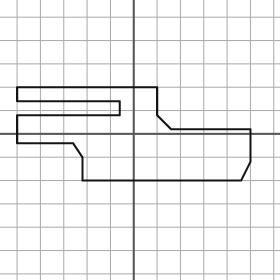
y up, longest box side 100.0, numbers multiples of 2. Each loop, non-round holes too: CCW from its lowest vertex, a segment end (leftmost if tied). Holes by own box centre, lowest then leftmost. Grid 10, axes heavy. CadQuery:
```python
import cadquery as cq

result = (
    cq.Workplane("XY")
    .moveTo(-22.0, -20.0)
    .lineTo(46.0, -20.0)
    .lineTo(50.0, -12.0)
    .lineTo(50.0, 2.0)
    .lineTo(16.0, 2.0)
    .lineTo(10.0, 8.0)
    .lineTo(10.0, 20.0)
    .lineTo(-50.0, 20.0)
    .lineTo(-50.0, 14.0)
    .lineTo(-6.0, 14.0)
    .lineTo(-6.0, 8.0)
    .lineTo(-50.0, 8.0)
    .lineTo(-50.0, -4.0)
    .lineTo(-26.0, -4.0)
    .lineTo(-22.0, -10.0)
    .close()
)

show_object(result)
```